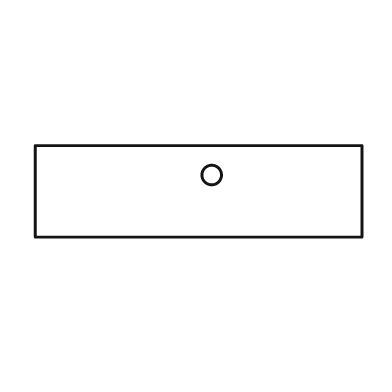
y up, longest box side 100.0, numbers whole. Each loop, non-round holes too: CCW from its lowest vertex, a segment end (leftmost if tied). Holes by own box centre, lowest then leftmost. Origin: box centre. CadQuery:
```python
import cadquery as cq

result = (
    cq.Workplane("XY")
    .moveTo(-50.0, -14.0)
    .lineTo(50.0, -14.0)
    .lineTo(50.0, 14.0)
    .lineTo(-50.0, 14.0)
    .close()
    .moveTo(4.0, 5.0)
    .circle(3.0)
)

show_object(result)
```